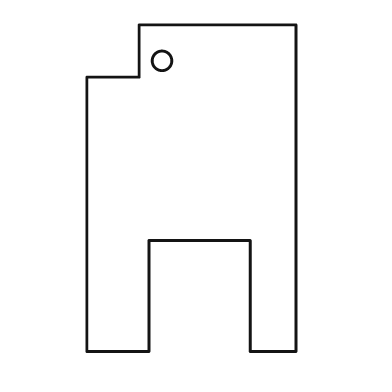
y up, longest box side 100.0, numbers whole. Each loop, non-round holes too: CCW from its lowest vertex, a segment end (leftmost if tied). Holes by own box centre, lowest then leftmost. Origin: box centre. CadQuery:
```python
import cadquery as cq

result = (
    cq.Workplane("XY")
    .moveTo(-32.0, -50.0)
    .lineTo(-13.0, -50.0)
    .lineTo(-13.0, -16.0)
    .lineTo(18.0, -16.0)
    .lineTo(18.0, -50.0)
    .lineTo(32.0, -50.0)
    .lineTo(32.0, 50.0)
    .lineTo(-16.0, 50.0)
    .lineTo(-16.0, 34.0)
    .lineTo(-32.0, 34.0)
    .close()
    .moveTo(-9.0, 39.0)
    .circle(3.0)
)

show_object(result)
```